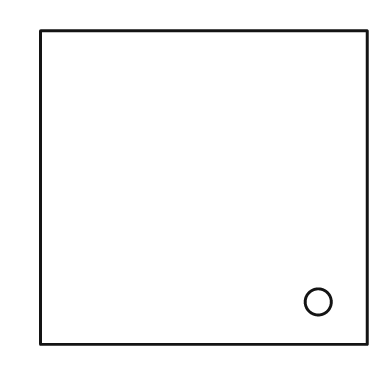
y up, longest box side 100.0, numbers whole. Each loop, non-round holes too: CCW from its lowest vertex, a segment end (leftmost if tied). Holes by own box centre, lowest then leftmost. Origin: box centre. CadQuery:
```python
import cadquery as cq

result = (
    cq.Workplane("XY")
    .moveTo(-50.0, -48.0)
    .lineTo(50.0, -48.0)
    .lineTo(50.0, 48.0)
    .lineTo(-50.0, 48.0)
    .close()
    .moveTo(35.0, -35.0)
    .circle(4.0)
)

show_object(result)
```